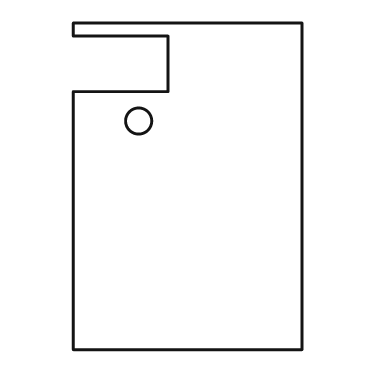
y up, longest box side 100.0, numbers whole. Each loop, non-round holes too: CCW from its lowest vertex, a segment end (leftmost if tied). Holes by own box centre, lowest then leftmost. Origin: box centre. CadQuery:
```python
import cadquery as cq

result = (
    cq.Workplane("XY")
    .moveTo(-35.0, -50.0)
    .lineTo(35.0, -50.0)
    .lineTo(35.0, 50.0)
    .lineTo(-35.0, 50.0)
    .lineTo(-35.0, 46.0)
    .lineTo(-6.0, 46.0)
    .lineTo(-6.0, 29.0)
    .lineTo(-35.0, 29.0)
    .close()
    .moveTo(-15.0, 20.0)
    .circle(4.0)
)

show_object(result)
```